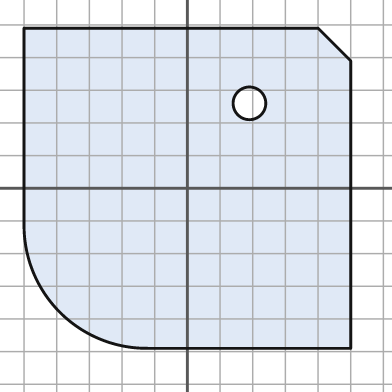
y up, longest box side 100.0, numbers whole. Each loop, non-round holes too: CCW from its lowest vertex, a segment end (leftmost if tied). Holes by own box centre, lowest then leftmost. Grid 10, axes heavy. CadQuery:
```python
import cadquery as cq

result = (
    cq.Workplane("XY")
    .moveTo(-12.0, -49.0)
    .lineTo(50.0, -49.0)
    .lineTo(50.0, 39.0)
    .lineTo(40.0, 49.0)
    .lineTo(-50.0, 49.0)
    .lineTo(-50.0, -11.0)
    .threePointArc((-39.0, -38.0), (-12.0, -49.0))
    .close()
    .moveTo(19.0, 26.0)
    .circle(5.0)
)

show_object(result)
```